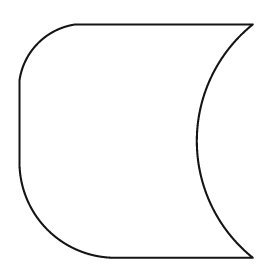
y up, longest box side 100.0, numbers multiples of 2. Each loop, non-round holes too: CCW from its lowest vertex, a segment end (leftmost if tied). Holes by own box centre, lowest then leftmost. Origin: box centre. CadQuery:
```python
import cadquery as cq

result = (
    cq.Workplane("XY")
    .moveTo(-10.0, -50.0)
    .lineTo(50.0, -50.0)
    .threePointArc((26.0, 0.0), (50.0, 50.0))
    .lineTo(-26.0, 50.0)
    .threePointArc((-42.0, 42.0), (-50.0, 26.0))
    .lineTo(-50.0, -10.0)
    .threePointArc((-38.0, -38.0), (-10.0, -50.0))
    .close()
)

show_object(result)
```